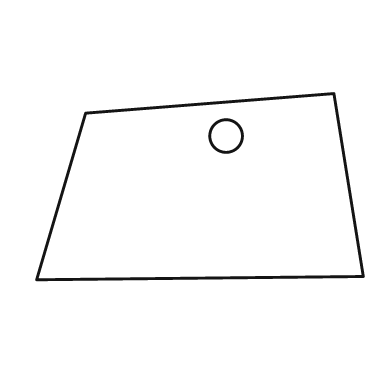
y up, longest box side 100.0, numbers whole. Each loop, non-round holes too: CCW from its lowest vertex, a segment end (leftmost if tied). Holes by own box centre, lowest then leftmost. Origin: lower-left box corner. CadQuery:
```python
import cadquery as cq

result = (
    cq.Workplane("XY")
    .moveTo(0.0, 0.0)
    .lineTo(100.0, 1.0)
    .lineTo(91.0, 57.0)
    .lineTo(15.0, 51.0)
    .close()
    .moveTo(58.0, 44.0)
    .circle(5.0)
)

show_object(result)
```